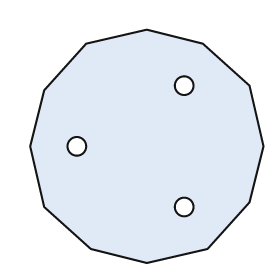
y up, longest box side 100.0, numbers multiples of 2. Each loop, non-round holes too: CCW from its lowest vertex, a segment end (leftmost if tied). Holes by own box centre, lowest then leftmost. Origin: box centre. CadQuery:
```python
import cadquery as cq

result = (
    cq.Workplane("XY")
    .moveTo(0.0, -50.0)
    .lineTo(26.0, -44.0)
    .lineTo(44.0, -24.0)
    .lineTo(50.0, 0.0)
    .lineTo(44.0, 26.0)
    .lineTo(24.0, 44.0)
    .lineTo(0.0, 50.0)
    .lineTo(-26.0, 44.0)
    .lineTo(-44.0, 24.0)
    .lineTo(-50.0, 0.0)
    .lineTo(-44.0, -26.0)
    .lineTo(-24.0, -44.0)
    .close()
    .moveTo(16.0, -26.0)
    .circle(4.0)
    .moveTo(-30.0, 0.0)
    .circle(4.0)
    .moveTo(16.0, 26.0)
    .circle(4.0)
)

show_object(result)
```